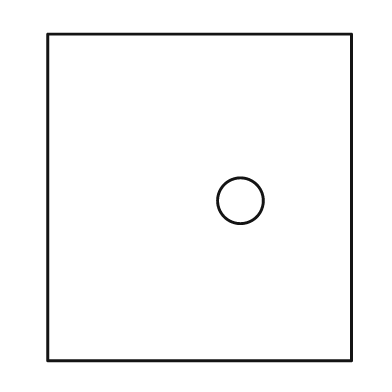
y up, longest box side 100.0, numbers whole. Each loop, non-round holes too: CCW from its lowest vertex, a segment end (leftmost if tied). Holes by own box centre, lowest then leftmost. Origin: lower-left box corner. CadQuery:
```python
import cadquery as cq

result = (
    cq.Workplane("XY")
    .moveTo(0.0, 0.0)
    .lineTo(93.0, 0.0)
    .lineTo(93.0, 100.0)
    .lineTo(0.0, 100.0)
    .close()
    .moveTo(59.0, 49.0)
    .circle(7.0)
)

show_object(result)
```